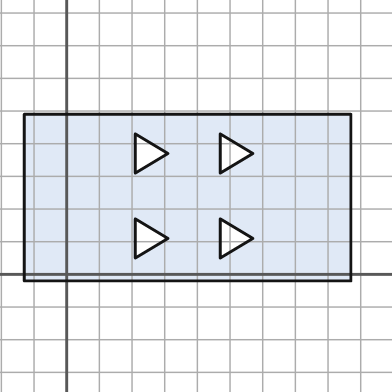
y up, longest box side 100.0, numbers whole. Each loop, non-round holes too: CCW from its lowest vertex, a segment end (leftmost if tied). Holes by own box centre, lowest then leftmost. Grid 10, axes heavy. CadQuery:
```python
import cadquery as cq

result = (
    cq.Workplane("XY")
    .moveTo(-13.0, -2.0)
    .lineTo(87.0, -2.0)
    .lineTo(87.0, 49.0)
    .lineTo(-13.0, 49.0)
    .close()
    .moveTo(21.0, 5.0)
    .lineTo(31.0, 11.0)
    .lineTo(21.0, 17.0)
    .close()
    .moveTo(47.0, 5.0)
    .lineTo(57.0, 11.0)
    .lineTo(47.0, 17.0)
    .close()
    .moveTo(21.0, 31.0)
    .lineTo(31.0, 37.0)
    .lineTo(21.0, 43.0)
    .close()
    .moveTo(47.0, 31.0)
    .lineTo(57.0, 37.0)
    .lineTo(47.0, 43.0)
    .close()
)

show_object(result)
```